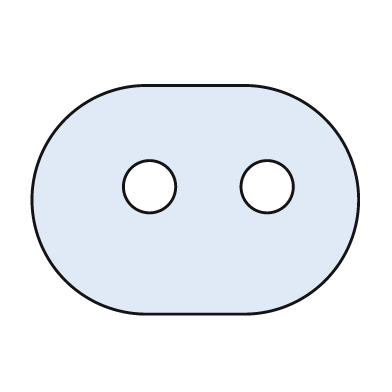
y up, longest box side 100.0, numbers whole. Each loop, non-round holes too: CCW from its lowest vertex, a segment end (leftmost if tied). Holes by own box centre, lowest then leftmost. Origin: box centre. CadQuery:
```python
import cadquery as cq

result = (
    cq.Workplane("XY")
    .moveTo(-15.0, -35.0)
    .lineTo(15.0, -35.0)
    .threePointArc((50.0, 0.0), (15.0, 35.0))
    .lineTo(-15.0, 35.0)
    .threePointArc((-50.0, 0.0), (-15.0, -35.0))
    .close()
    .moveTo(-14.0, 4.0)
    .circle(8.0)
    .moveTo(22.0, 4.0)
    .circle(8.0)
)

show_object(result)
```